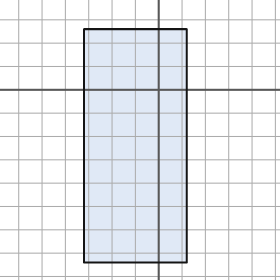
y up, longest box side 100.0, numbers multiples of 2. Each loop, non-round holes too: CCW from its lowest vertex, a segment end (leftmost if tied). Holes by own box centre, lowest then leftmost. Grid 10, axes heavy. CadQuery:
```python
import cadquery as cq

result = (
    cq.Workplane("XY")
    .moveTo(-32.0, -74.0)
    .lineTo(12.0, -74.0)
    .lineTo(12.0, 26.0)
    .lineTo(-32.0, 26.0)
    .close()
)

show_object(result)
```